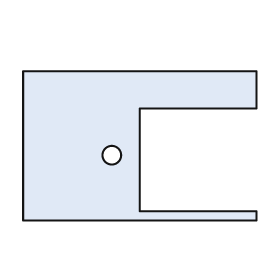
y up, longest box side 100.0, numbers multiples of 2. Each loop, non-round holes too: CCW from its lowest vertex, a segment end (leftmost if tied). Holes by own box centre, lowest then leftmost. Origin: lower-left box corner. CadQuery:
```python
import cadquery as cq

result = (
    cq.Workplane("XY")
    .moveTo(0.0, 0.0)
    .lineTo(100.0, 0.0)
    .lineTo(100.0, 4.0)
    .lineTo(50.0, 4.0)
    .lineTo(50.0, 48.0)
    .lineTo(100.0, 48.0)
    .lineTo(100.0, 64.0)
    .lineTo(0.0, 64.0)
    .close()
    .moveTo(38.0, 28.0)
    .circle(4.0)
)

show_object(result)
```